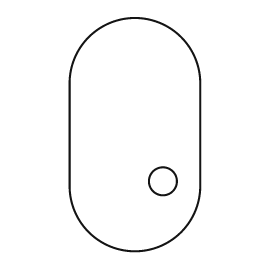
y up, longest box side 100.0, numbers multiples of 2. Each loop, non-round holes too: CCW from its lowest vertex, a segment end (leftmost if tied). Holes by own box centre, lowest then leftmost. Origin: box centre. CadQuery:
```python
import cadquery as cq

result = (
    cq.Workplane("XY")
    .moveTo(-28.0, -22.0)
    .threePointArc((0.0, -50.0), (28.0, -22.0))
    .lineTo(28.0, 22.0)
    .threePointArc((0.0, 50.0), (-28.0, 22.0))
    .close()
    .moveTo(12.0, -20.0)
    .circle(6.0)
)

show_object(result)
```